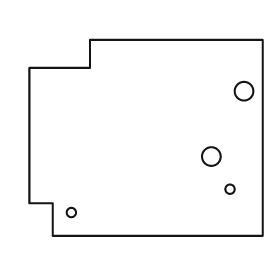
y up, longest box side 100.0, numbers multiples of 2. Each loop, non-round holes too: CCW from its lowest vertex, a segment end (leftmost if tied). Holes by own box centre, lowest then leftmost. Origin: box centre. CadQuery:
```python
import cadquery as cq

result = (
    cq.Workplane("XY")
    .moveTo(-40.0, -42.0)
    .lineTo(50.0, -42.0)
    .lineTo(50.0, 42.0)
    .lineTo(-24.0, 42.0)
    .lineTo(-24.0, 30.0)
    .lineTo(-50.0, 30.0)
    .lineTo(-50.0, -28.0)
    .lineTo(-40.0, -28.0)
    .close()
    .moveTo(-32.0, -32.0)
    .circle(2.0)
    .moveTo(36.0, -22.0)
    .circle(2.0)
    .moveTo(28.0, -8.0)
    .circle(4.0)
    .moveTo(42.0, 20.0)
    .circle(4.0)
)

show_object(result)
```